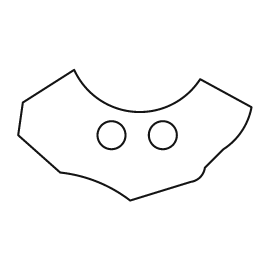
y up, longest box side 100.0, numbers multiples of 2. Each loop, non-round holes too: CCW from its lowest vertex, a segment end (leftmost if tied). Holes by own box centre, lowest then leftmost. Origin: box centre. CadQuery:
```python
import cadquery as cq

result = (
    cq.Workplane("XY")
    .moveTo(-2.0, -28.0)
    .lineTo(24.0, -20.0)
    .threePointArc((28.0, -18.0), (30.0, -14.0))
    .lineTo(38.0, -6.0)
    .threePointArc((46.0, 2.0), (50.0, 12.0))
    .lineTo(28.0, 24.0)
    .threePointArc((0.0, 10.0), (-26.0, 28.0))
    .lineTo(-48.0, 14.0)
    .lineTo(-50.0, 0.0)
    .lineTo(-32.0, -16.0)
    .threePointArc((-16.0, -20.0), (-2.0, -28.0))
    .close()
    .moveTo(-10.0, 0.0)
    .circle(6.0)
    .moveTo(12.0, 0.0)
    .circle(6.0)
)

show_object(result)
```